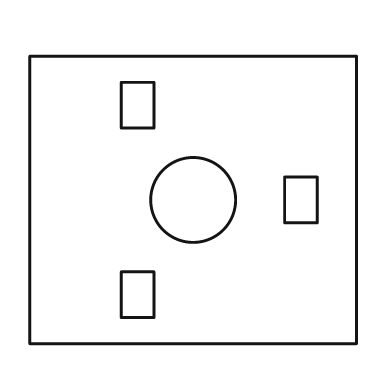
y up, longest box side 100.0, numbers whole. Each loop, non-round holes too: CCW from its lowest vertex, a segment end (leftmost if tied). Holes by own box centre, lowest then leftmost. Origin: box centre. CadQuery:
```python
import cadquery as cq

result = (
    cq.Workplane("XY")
    .moveTo(-50.0, -44.0)
    .lineTo(50.0, -44.0)
    .lineTo(50.0, 44.0)
    .lineTo(-50.0, 44.0)
    .close()
    .moveTo(-22.0, -36.0)
    .lineTo(-12.0, -36.0)
    .lineTo(-12.0, -22.0)
    .lineTo(-22.0, -22.0)
    .close()
    .moveTo(0.0, 0.0)
    .circle(13.0)
    .moveTo(28.0, -7.0)
    .lineTo(38.0, -7.0)
    .lineTo(38.0, 7.0)
    .lineTo(28.0, 7.0)
    .close()
    .moveTo(-22.0, 22.0)
    .lineTo(-12.0, 22.0)
    .lineTo(-12.0, 36.0)
    .lineTo(-22.0, 36.0)
    .close()
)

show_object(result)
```